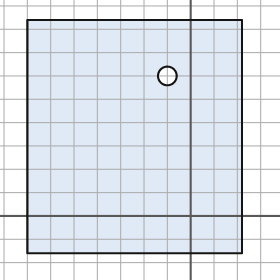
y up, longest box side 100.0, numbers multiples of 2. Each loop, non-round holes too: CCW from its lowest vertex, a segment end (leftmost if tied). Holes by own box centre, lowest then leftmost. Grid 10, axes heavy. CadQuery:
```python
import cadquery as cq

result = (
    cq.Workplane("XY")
    .moveTo(-70.0, -16.0)
    .lineTo(22.0, -16.0)
    .lineTo(22.0, 84.0)
    .lineTo(-70.0, 84.0)
    .close()
    .moveTo(-10.0, 60.0)
    .circle(4.0)
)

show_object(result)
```